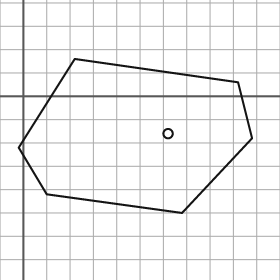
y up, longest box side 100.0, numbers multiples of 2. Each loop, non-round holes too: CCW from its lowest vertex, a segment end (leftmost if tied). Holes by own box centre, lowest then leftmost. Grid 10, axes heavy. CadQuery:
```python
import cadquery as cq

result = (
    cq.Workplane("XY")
    .moveTo(68.0, -50.0)
    .lineTo(98.0, -18.0)
    .lineTo(92.0, 6.0)
    .lineTo(22.0, 16.0)
    .lineTo(-2.0, -22.0)
    .lineTo(10.0, -42.0)
    .close()
    .moveTo(62.0, -16.0)
    .circle(2.0)
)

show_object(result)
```